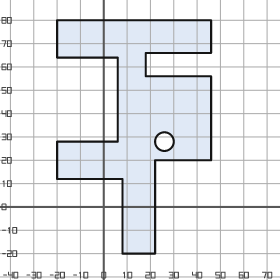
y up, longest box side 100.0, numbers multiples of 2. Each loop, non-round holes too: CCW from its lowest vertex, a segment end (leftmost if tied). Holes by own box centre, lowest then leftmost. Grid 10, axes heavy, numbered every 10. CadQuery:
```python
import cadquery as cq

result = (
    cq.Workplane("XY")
    .moveTo(8.0, -20.0)
    .lineTo(22.0, -20.0)
    .lineTo(22.0, 20.0)
    .lineTo(46.0, 20.0)
    .lineTo(46.0, 56.0)
    .lineTo(18.0, 56.0)
    .lineTo(18.0, 66.0)
    .lineTo(46.0, 66.0)
    .lineTo(46.0, 80.0)
    .lineTo(-20.0, 80.0)
    .lineTo(-20.0, 64.0)
    .lineTo(6.0, 64.0)
    .lineTo(6.0, 28.0)
    .lineTo(-20.0, 28.0)
    .lineTo(-20.0, 12.0)
    .lineTo(8.0, 12.0)
    .close()
    .moveTo(26.0, 28.0)
    .circle(4.0)
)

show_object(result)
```